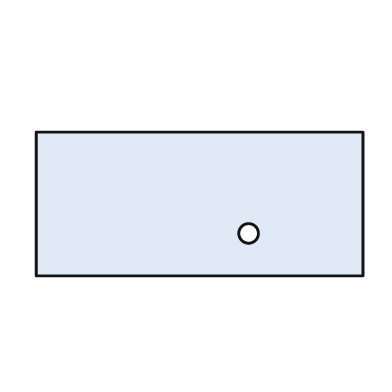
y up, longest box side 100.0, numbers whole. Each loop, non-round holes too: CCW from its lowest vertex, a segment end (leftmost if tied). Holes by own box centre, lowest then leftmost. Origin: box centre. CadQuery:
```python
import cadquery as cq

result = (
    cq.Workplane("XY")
    .moveTo(-50.0, -22.0)
    .lineTo(50.0, -22.0)
    .lineTo(50.0, 22.0)
    .lineTo(-50.0, 22.0)
    .close()
    .moveTo(15.0, -9.0)
    .circle(3.0)
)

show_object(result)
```